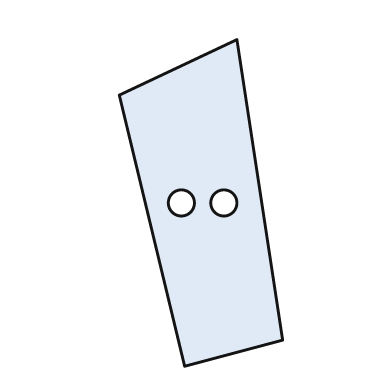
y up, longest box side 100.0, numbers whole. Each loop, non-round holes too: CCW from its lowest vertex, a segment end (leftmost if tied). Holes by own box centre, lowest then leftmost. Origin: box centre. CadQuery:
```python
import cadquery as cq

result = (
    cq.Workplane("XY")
    .moveTo(-5.0, -50.0)
    .lineTo(25.0, -42.0)
    .lineTo(11.0, 50.0)
    .lineTo(-25.0, 33.0)
    .close()
    .moveTo(-6.0, 0.0)
    .circle(4.0)
    .moveTo(7.0, 0.0)
    .circle(4.0)
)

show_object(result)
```